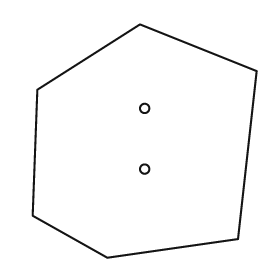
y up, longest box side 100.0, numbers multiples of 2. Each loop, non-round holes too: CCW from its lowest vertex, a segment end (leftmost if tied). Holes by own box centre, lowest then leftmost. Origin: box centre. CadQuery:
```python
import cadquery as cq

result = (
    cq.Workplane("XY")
    .moveTo(-16.0, -50.0)
    .lineTo(40.0, -42.0)
    .lineTo(48.0, 30.0)
    .lineTo(-2.0, 50.0)
    .lineTo(-46.0, 22.0)
    .lineTo(-48.0, -32.0)
    .close()
    .moveTo(0.0, -12.0)
    .circle(2.0)
    .moveTo(0.0, 14.0)
    .circle(2.0)
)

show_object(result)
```